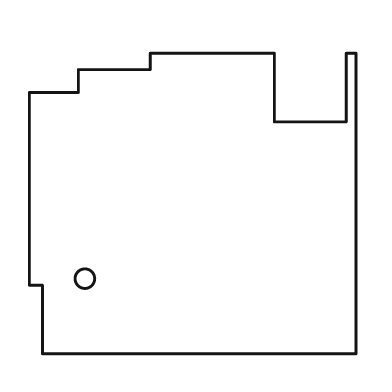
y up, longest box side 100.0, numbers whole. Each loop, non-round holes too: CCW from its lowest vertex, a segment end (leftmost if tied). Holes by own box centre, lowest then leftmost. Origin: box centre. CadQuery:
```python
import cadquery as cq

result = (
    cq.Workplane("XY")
    .moveTo(-46.0, -46.0)
    .lineTo(50.0, -46.0)
    .lineTo(50.0, 46.0)
    .lineTo(47.0, 46.0)
    .lineTo(47.0, 25.0)
    .lineTo(25.0, 25.0)
    .lineTo(25.0, 46.0)
    .lineTo(-13.0, 46.0)
    .lineTo(-13.0, 41.0)
    .lineTo(-35.0, 41.0)
    .lineTo(-35.0, 34.0)
    .lineTo(-50.0, 34.0)
    .lineTo(-50.0, -25.0)
    .lineTo(-46.0, -25.0)
    .close()
    .moveTo(-33.0, -23.0)
    .circle(3.0)
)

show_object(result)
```